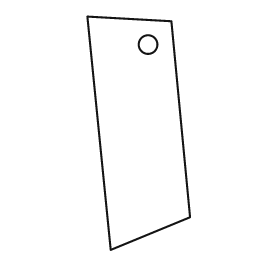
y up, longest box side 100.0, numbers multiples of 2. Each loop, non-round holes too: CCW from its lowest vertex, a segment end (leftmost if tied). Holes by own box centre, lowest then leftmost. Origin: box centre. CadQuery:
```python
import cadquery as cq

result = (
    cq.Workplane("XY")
    .moveTo(-12.0, -50.0)
    .lineTo(22.0, -36.0)
    .lineTo(14.0, 48.0)
    .lineTo(-22.0, 50.0)
    .close()
    .moveTo(4.0, 38.0)
    .circle(4.0)
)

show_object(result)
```